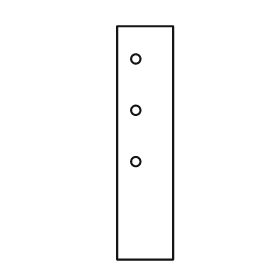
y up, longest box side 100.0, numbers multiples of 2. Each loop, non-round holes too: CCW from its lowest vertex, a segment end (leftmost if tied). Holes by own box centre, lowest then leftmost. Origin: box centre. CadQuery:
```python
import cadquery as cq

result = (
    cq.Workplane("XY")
    .moveTo(-12.0, -50.0)
    .lineTo(12.0, -50.0)
    .lineTo(12.0, 50.0)
    .lineTo(-12.0, 50.0)
    .close()
    .moveTo(-4.0, -8.0)
    .circle(2.0)
    .moveTo(-4.0, 14.0)
    .circle(2.0)
    .moveTo(-4.0, 36.0)
    .circle(2.0)
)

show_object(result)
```